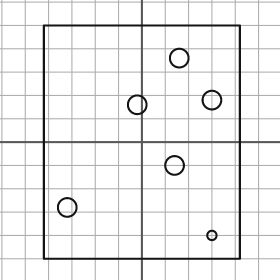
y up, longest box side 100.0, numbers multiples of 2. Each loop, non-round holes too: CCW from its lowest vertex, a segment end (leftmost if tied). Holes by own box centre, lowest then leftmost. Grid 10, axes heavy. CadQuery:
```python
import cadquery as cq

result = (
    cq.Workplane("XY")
    .moveTo(-42.0, -50.0)
    .lineTo(42.0, -50.0)
    .lineTo(42.0, 50.0)
    .lineTo(-42.0, 50.0)
    .close()
    .moveTo(30.0, -40.0)
    .circle(2.0)
    .moveTo(-32.0, -28.0)
    .circle(4.0)
    .moveTo(14.0, -10.0)
    .circle(4.0)
    .moveTo(-2.0, 16.0)
    .circle(4.0)
    .moveTo(30.0, 18.0)
    .circle(4.0)
    .moveTo(16.0, 36.0)
    .circle(4.0)
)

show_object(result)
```